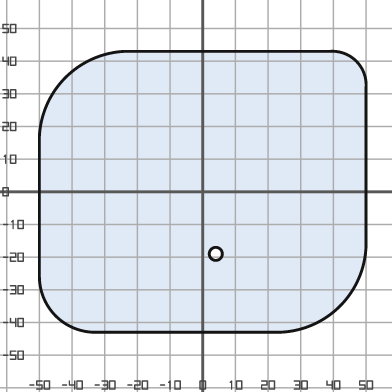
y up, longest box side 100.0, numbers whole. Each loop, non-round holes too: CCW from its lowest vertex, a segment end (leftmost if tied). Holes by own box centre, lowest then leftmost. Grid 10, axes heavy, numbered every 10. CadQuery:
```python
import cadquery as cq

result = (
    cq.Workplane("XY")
    .moveTo(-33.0, -43.0)
    .lineTo(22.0, -43.0)
    .threePointArc((42.0, -35.0), (50.0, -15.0))
    .lineTo(50.0, 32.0)
    .threePointArc((47.0, 40.0), (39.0, 43.0))
    .lineTo(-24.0, 43.0)
    .threePointArc((-42.0, 35.0), (-50.0, 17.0))
    .lineTo(-50.0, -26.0)
    .threePointArc((-45.0, -38.0), (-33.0, -43.0))
    .close()
    .moveTo(4.0, -19.0)
    .circle(2.0)
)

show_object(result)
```